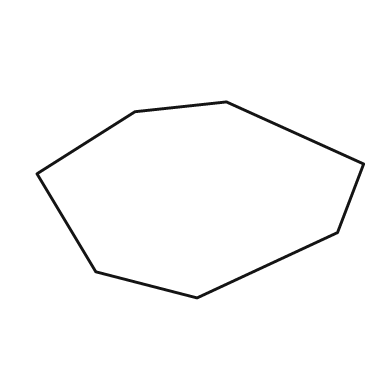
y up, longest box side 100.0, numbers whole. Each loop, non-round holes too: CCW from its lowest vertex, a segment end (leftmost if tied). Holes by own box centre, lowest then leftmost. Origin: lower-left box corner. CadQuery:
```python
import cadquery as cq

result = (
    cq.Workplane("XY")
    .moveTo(49.0, 0.0)
    .lineTo(92.0, 20.0)
    .lineTo(100.0, 41.0)
    .lineTo(58.0, 60.0)
    .lineTo(30.0, 57.0)
    .lineTo(0.0, 38.0)
    .lineTo(18.0, 8.0)
    .close()
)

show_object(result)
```